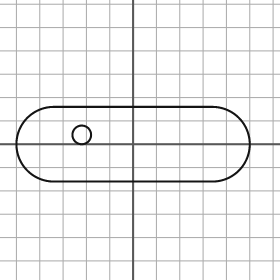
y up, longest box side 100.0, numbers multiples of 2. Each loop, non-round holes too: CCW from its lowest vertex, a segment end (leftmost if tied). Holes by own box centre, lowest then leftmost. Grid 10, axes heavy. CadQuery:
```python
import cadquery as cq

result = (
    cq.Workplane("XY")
    .moveTo(-34.0, -16.0)
    .lineTo(34.0, -16.0)
    .threePointArc((50.0, 0.0), (34.0, 16.0))
    .lineTo(-34.0, 16.0)
    .threePointArc((-50.0, 0.0), (-34.0, -16.0))
    .close()
    .moveTo(-22.0, 4.0)
    .circle(4.0)
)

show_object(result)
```